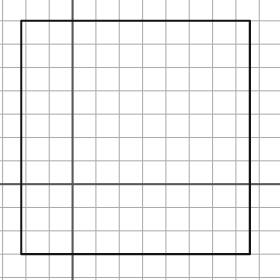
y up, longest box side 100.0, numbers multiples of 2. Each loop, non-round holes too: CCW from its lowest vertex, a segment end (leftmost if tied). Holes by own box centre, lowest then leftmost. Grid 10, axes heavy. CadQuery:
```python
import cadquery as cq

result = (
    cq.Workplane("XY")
    .moveTo(-22.0, -30.0)
    .lineTo(76.0, -30.0)
    .lineTo(76.0, 70.0)
    .lineTo(-22.0, 70.0)
    .close()
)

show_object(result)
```